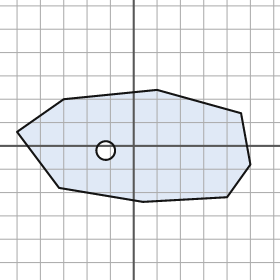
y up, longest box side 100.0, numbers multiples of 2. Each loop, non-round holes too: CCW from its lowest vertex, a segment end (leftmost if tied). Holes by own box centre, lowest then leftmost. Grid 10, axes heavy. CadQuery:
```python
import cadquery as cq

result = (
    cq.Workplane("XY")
    .moveTo(4.0, -24.0)
    .lineTo(40.0, -22.0)
    .lineTo(50.0, -8.0)
    .lineTo(46.0, 14.0)
    .lineTo(10.0, 24.0)
    .lineTo(-30.0, 20.0)
    .lineTo(-50.0, 6.0)
    .lineTo(-32.0, -18.0)
    .close()
    .moveTo(-12.0, -2.0)
    .circle(4.0)
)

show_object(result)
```